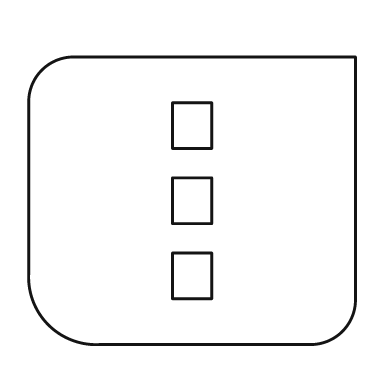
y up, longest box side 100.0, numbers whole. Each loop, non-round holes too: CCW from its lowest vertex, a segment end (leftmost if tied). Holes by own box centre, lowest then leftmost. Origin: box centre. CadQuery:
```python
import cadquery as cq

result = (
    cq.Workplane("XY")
    .moveTo(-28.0, -44.0)
    .lineTo(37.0, -44.0)
    .threePointArc((46.0, -40.0), (50.0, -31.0))
    .lineTo(50.0, 44.0)
    .lineTo(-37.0, 44.0)
    .threePointArc((-46.0, 40.0), (-50.0, 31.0))
    .lineTo(-50.0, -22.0)
    .threePointArc((-44.0, -38.0), (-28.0, -44.0))
    .close()
    .moveTo(-6.0, -30.0)
    .lineTo(6.0, -30.0)
    .lineTo(6.0, -16.0)
    .lineTo(-6.0, -16.0)
    .close()
    .moveTo(-6.0, -7.0)
    .lineTo(6.0, -7.0)
    .lineTo(6.0, 7.0)
    .lineTo(-6.0, 7.0)
    .close()
    .moveTo(-6.0, 16.0)
    .lineTo(6.0, 16.0)
    .lineTo(6.0, 30.0)
    .lineTo(-6.0, 30.0)
    .close()
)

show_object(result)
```